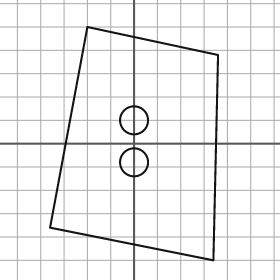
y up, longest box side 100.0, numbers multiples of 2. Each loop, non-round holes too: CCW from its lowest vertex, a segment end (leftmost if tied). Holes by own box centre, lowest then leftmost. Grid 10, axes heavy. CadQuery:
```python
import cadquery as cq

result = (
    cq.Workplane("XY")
    .moveTo(34.0, -50.0)
    .lineTo(36.0, 38.0)
    .lineTo(-20.0, 50.0)
    .lineTo(-36.0, -36.0)
    .close()
    .moveTo(0.0, -8.0)
    .circle(6.0)
    .moveTo(0.0, 10.0)
    .circle(6.0)
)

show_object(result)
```